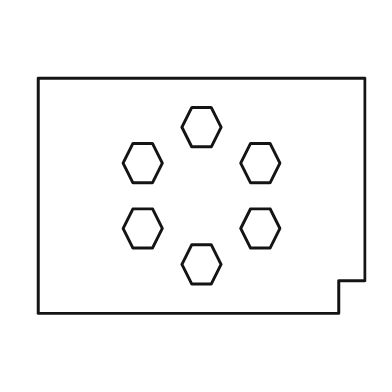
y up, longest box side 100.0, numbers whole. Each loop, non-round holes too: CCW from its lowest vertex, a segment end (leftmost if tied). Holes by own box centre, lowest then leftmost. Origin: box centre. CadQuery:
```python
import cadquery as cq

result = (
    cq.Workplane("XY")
    .moveTo(-50.0, -36.0)
    .lineTo(42.0, -36.0)
    .lineTo(42.0, -26.0)
    .lineTo(50.0, -26.0)
    .lineTo(50.0, 36.0)
    .lineTo(-50.0, 36.0)
    .close()
    .moveTo(-3.0, -27.0)
    .lineTo(3.0, -27.0)
    .lineTo(6.0, -21.0)
    .lineTo(3.0, -15.0)
    .lineTo(-3.0, -15.0)
    .lineTo(-6.0, -21.0)
    .close()
    .moveTo(-21.0, -16.0)
    .lineTo(-15.0, -16.0)
    .lineTo(-12.0, -10.0)
    .lineTo(-15.0, -4.0)
    .lineTo(-21.0, -4.0)
    .lineTo(-24.0, -10.0)
    .close()
    .moveTo(15.0, -16.0)
    .lineTo(21.0, -16.0)
    .lineTo(24.0, -10.0)
    .lineTo(21.0, -4.0)
    .lineTo(15.0, -4.0)
    .lineTo(12.0, -10.0)
    .close()
    .moveTo(-21.0, 4.0)
    .lineTo(-15.0, 4.0)
    .lineTo(-12.0, 10.0)
    .lineTo(-15.0, 16.0)
    .lineTo(-21.0, 16.0)
    .lineTo(-24.0, 10.0)
    .close()
    .moveTo(15.0, 4.0)
    .lineTo(21.0, 4.0)
    .lineTo(24.0, 10.0)
    .lineTo(21.0, 16.0)
    .lineTo(15.0, 16.0)
    .lineTo(12.0, 10.0)
    .close()
    .moveTo(-3.0, 15.0)
    .lineTo(3.0, 15.0)
    .lineTo(6.0, 21.0)
    .lineTo(3.0, 27.0)
    .lineTo(-3.0, 27.0)
    .lineTo(-6.0, 21.0)
    .close()
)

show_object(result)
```